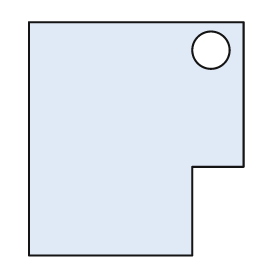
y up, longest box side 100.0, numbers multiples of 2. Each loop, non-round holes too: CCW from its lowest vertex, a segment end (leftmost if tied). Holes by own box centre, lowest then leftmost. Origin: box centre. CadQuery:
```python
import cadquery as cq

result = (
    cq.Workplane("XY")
    .moveTo(-46.0, -50.0)
    .lineTo(24.0, -50.0)
    .lineTo(24.0, -12.0)
    .lineTo(46.0, -12.0)
    .lineTo(46.0, 50.0)
    .lineTo(-46.0, 50.0)
    .close()
    .moveTo(32.0, 38.0)
    .circle(8.0)
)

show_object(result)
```